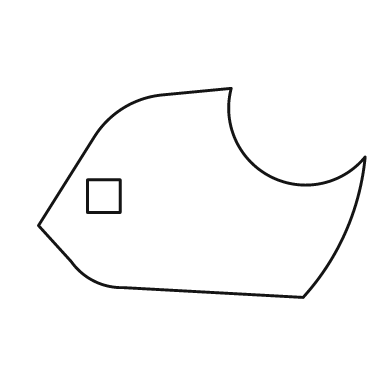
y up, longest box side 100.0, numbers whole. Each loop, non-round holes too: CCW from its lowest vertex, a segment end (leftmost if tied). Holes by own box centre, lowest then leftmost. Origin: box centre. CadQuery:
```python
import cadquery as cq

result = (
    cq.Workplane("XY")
    .moveTo(31.0, -32.0)
    .threePointArc((44.0, -12.0), (50.0, 11.0))
    .threePointArc((21.0, 5.0), (9.0, 32.0))
    .lineTo(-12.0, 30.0)
    .threePointArc((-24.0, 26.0), (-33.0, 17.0))
    .lineTo(-50.0, -10.0)
    .lineTo(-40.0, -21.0)
    .threePointArc((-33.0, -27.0), (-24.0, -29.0))
    .close()
    .moveTo(-35.0, -6.0)
    .lineTo(-25.0, -6.0)
    .lineTo(-25.0, 4.0)
    .lineTo(-35.0, 4.0)
    .close()
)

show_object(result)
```